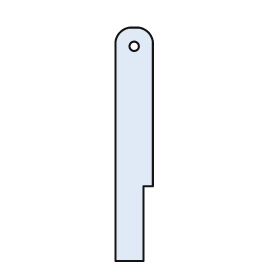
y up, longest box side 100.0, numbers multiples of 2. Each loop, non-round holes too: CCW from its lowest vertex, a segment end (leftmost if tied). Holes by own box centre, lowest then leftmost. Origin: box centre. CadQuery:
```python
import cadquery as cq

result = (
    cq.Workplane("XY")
    .moveTo(-8.0, -50.0)
    .lineTo(4.0, -50.0)
    .lineTo(4.0, -18.0)
    .lineTo(8.0, -18.0)
    .lineTo(8.0, 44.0)
    .threePointArc((6.0, 48.0), (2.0, 50.0))
    .lineTo(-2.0, 50.0)
    .threePointArc((-6.0, 48.0), (-8.0, 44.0))
    .close()
    .moveTo(0.0, 42.0)
    .circle(2.0)
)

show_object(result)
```